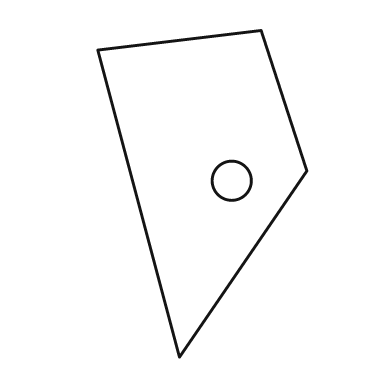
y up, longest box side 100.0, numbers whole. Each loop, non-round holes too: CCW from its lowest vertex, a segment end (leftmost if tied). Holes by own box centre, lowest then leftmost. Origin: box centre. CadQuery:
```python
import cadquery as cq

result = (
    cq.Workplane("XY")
    .moveTo(-7.0, -50.0)
    .lineTo(32.0, 7.0)
    .lineTo(18.0, 50.0)
    .lineTo(-32.0, 44.0)
    .close()
    .moveTo(9.0, 4.0)
    .circle(6.0)
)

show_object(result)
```